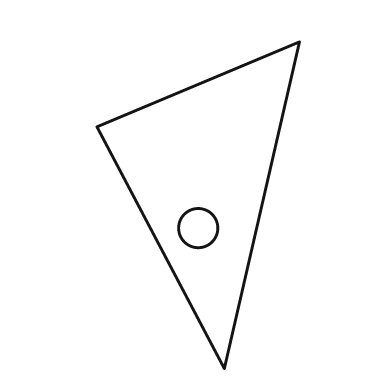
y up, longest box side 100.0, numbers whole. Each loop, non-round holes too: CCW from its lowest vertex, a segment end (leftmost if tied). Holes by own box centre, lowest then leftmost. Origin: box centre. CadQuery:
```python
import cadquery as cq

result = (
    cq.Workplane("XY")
    .moveTo(8.0, -50.0)
    .lineTo(31.0, 50.0)
    .lineTo(-31.0, 24.0)
    .close()
    .moveTo(0.0, -7.0)
    .circle(6.0)
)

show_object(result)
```